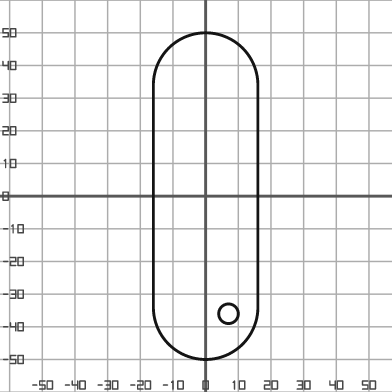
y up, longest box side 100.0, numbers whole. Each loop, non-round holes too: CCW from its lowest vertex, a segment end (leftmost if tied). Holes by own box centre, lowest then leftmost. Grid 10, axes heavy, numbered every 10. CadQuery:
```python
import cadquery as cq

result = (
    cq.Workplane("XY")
    .moveTo(-16.0, -34.0)
    .threePointArc((0.0, -50.0), (16.0, -34.0))
    .lineTo(16.0, 34.0)
    .threePointArc((0.0, 50.0), (-16.0, 34.0))
    .close()
    .moveTo(7.0, -36.0)
    .circle(3.0)
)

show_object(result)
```